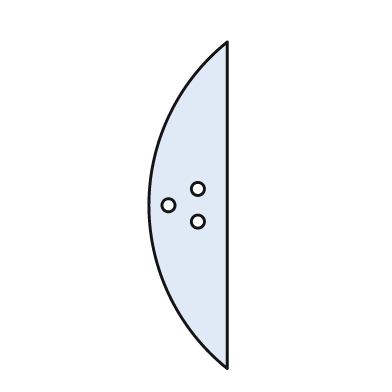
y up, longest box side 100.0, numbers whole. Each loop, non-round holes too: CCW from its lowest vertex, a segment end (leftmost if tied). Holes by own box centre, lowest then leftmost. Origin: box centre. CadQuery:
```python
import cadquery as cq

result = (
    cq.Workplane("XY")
    .moveTo(12.0, -50.0)
    .lineTo(12.0, 50.0)
    .threePointArc((-12.0, 0.0), (12.0, -50.0))
    .close()
    .moveTo(3.0, -5.0)
    .circle(2.0)
    .moveTo(-6.0, 0.0)
    .circle(2.0)
    .moveTo(3.0, 5.0)
    .circle(2.0)
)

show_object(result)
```